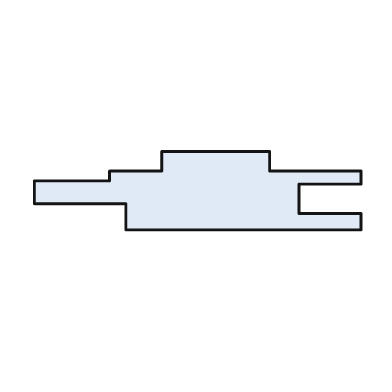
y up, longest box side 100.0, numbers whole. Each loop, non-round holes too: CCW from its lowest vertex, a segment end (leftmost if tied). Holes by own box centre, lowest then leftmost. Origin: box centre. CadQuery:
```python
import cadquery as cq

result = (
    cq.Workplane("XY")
    .moveTo(-22.0, -12.0)
    .lineTo(50.0, -12.0)
    .lineTo(50.0, -7.0)
    .lineTo(31.0, -7.0)
    .lineTo(31.0, 2.0)
    .lineTo(50.0, 2.0)
    .lineTo(50.0, 6.0)
    .lineTo(22.0, 6.0)
    .lineTo(22.0, 12.0)
    .lineTo(-11.0, 12.0)
    .lineTo(-11.0, 6.0)
    .lineTo(-27.0, 6.0)
    .lineTo(-27.0, 3.0)
    .lineTo(-50.0, 3.0)
    .lineTo(-50.0, -4.0)
    .lineTo(-22.0, -4.0)
    .close()
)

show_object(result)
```